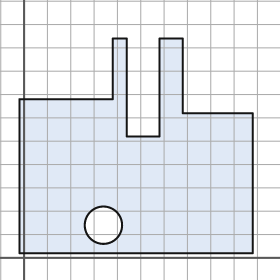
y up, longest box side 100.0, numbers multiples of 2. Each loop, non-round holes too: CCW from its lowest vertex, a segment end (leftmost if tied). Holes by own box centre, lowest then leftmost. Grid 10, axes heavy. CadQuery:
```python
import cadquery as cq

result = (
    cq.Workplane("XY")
    .moveTo(-2.0, 2.0)
    .lineTo(98.0, 2.0)
    .lineTo(98.0, 62.0)
    .lineTo(68.0, 62.0)
    .lineTo(68.0, 94.0)
    .lineTo(58.0, 94.0)
    .lineTo(58.0, 52.0)
    .lineTo(44.0, 52.0)
    .lineTo(44.0, 94.0)
    .lineTo(38.0, 94.0)
    .lineTo(38.0, 68.0)
    .lineTo(-2.0, 68.0)
    .close()
    .moveTo(34.0, 14.0)
    .circle(8.0)
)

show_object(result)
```